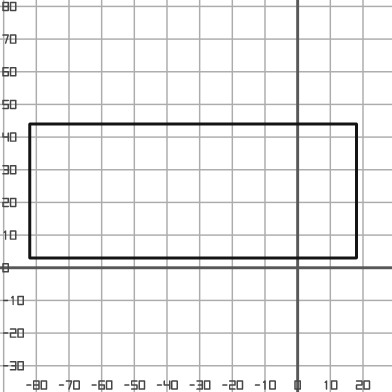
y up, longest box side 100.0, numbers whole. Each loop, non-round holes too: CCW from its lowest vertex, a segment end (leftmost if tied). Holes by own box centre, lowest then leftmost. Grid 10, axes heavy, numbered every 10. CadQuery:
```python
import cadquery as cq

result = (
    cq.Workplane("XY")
    .moveTo(-82.0, 3.0)
    .lineTo(18.0, 3.0)
    .lineTo(18.0, 44.0)
    .lineTo(-82.0, 44.0)
    .close()
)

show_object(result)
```